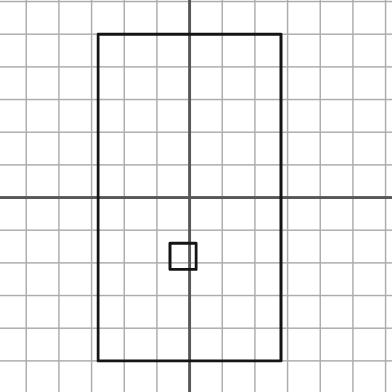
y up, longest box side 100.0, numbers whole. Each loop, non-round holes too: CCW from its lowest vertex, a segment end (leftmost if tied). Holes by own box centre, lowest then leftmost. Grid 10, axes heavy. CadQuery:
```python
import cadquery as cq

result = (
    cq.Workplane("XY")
    .moveTo(-28.0, -50.0)
    .lineTo(28.0, -50.0)
    .lineTo(28.0, 50.0)
    .lineTo(-28.0, 50.0)
    .close()
    .moveTo(-6.0, -22.0)
    .lineTo(2.0, -22.0)
    .lineTo(2.0, -14.0)
    .lineTo(-6.0, -14.0)
    .close()
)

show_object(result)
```